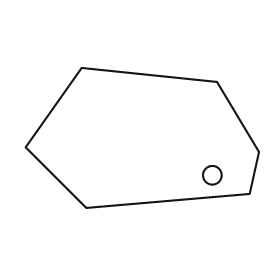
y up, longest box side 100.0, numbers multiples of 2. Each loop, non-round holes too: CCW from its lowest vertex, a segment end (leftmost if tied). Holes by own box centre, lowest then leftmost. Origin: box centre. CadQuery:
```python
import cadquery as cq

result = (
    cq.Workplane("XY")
    .moveTo(-24.0, -30.0)
    .lineTo(46.0, -24.0)
    .lineTo(50.0, -6.0)
    .lineTo(32.0, 24.0)
    .lineTo(-26.0, 30.0)
    .lineTo(-50.0, -4.0)
    .close()
    .moveTo(30.0, -16.0)
    .circle(4.0)
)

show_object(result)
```